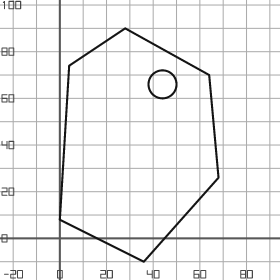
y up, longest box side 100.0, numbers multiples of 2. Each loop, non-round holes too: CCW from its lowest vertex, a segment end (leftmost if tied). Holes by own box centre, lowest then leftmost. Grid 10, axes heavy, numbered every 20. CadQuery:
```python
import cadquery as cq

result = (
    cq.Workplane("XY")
    .moveTo(36.0, -10.0)
    .lineTo(68.0, 26.0)
    .lineTo(64.0, 70.0)
    .lineTo(28.0, 90.0)
    .lineTo(4.0, 74.0)
    .lineTo(0.0, 8.0)
    .close()
    .moveTo(44.0, 66.0)
    .circle(6.0)
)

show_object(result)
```